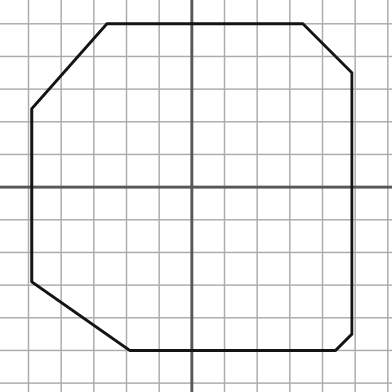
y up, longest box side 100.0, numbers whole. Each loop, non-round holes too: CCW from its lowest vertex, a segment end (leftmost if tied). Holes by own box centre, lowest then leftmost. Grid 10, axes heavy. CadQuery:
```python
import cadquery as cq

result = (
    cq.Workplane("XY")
    .moveTo(-19.0, -50.0)
    .lineTo(44.0, -50.0)
    .lineTo(49.0, -45.0)
    .lineTo(49.0, 35.0)
    .lineTo(34.0, 50.0)
    .lineTo(-26.0, 50.0)
    .lineTo(-49.0, 24.0)
    .lineTo(-49.0, -29.0)
    .close()
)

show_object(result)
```